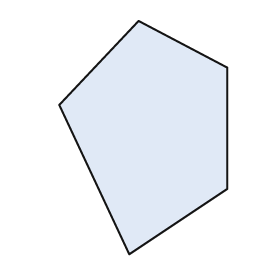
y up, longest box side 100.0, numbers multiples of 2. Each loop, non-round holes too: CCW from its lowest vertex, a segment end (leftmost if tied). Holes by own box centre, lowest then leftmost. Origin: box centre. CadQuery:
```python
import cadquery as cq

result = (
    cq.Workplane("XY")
    .moveTo(-6.0, -50.0)
    .lineTo(36.0, -22.0)
    .lineTo(36.0, 30.0)
    .lineTo(-2.0, 50.0)
    .lineTo(-36.0, 14.0)
    .close()
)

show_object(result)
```